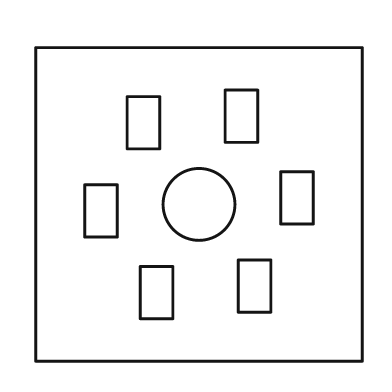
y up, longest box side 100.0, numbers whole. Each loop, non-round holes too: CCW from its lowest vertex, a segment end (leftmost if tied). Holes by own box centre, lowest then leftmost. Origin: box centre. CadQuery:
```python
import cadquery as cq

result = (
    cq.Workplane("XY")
    .moveTo(-50.0, -48.0)
    .lineTo(50.0, -48.0)
    .lineTo(50.0, 48.0)
    .lineTo(-50.0, 48.0)
    .close()
    .moveTo(-18.0, -35.0)
    .lineTo(-8.0, -35.0)
    .lineTo(-8.0, -19.0)
    .lineTo(-18.0, -19.0)
    .close()
    .moveTo(12.0, -33.0)
    .lineTo(22.0, -33.0)
    .lineTo(22.0, -17.0)
    .lineTo(12.0, -17.0)
    .close()
    .moveTo(-35.0, -10.0)
    .lineTo(-25.0, -10.0)
    .lineTo(-25.0, 6.0)
    .lineTo(-35.0, 6.0)
    .close()
    .moveTo(0.0, 0.0)
    .circle(11.0)
    .moveTo(25.0, -6.0)
    .lineTo(35.0, -6.0)
    .lineTo(35.0, 10.0)
    .lineTo(25.0, 10.0)
    .close()
    .moveTo(-22.0, 17.0)
    .lineTo(-12.0, 17.0)
    .lineTo(-12.0, 33.0)
    .lineTo(-22.0, 33.0)
    .close()
    .moveTo(8.0, 19.0)
    .lineTo(18.0, 19.0)
    .lineTo(18.0, 35.0)
    .lineTo(8.0, 35.0)
    .close()
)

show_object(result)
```